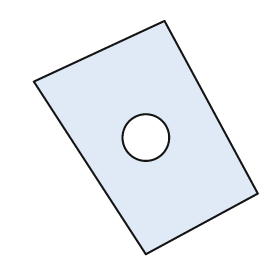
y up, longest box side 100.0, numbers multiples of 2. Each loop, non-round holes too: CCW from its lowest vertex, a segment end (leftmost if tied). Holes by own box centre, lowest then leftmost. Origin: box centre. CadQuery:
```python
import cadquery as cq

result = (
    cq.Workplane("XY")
    .moveTo(0.0, -50.0)
    .lineTo(48.0, -24.0)
    .lineTo(8.0, 50.0)
    .lineTo(-48.0, 24.0)
    .close()
    .moveTo(0.0, 0.0)
    .circle(10.0)
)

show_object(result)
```